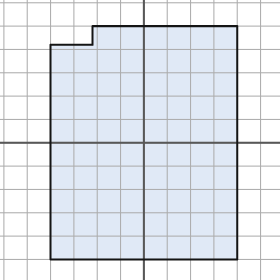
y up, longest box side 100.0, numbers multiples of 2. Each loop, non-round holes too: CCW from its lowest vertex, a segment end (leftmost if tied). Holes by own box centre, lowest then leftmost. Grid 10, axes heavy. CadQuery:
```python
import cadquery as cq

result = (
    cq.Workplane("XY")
    .moveTo(-40.0, -50.0)
    .lineTo(40.0, -50.0)
    .lineTo(40.0, 50.0)
    .lineTo(-22.0, 50.0)
    .lineTo(-22.0, 42.0)
    .lineTo(-40.0, 42.0)
    .close()
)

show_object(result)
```